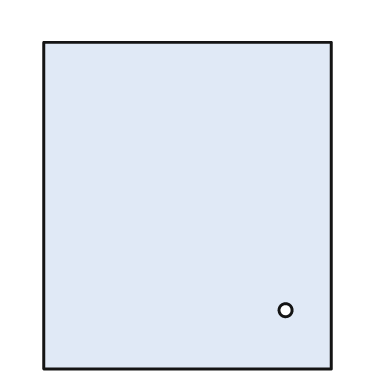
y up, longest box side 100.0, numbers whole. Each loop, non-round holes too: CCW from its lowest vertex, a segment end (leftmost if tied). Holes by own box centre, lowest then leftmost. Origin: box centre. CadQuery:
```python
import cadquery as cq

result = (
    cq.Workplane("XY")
    .moveTo(-44.0, -50.0)
    .lineTo(44.0, -50.0)
    .lineTo(44.0, 50.0)
    .lineTo(-44.0, 50.0)
    .close()
    .moveTo(30.0, -32.0)
    .circle(2.0)
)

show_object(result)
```